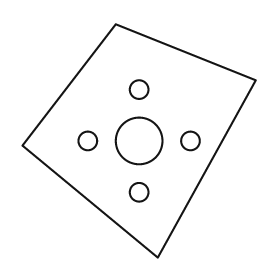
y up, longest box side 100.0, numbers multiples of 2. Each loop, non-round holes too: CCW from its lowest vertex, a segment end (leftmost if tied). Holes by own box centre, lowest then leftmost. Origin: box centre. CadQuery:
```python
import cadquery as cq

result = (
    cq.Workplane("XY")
    .moveTo(8.0, -50.0)
    .lineTo(50.0, 26.0)
    .lineTo(-10.0, 50.0)
    .lineTo(-50.0, -2.0)
    .close()
    .moveTo(0.0, -22.0)
    .circle(4.0)
    .moveTo(-22.0, 0.0)
    .circle(4.0)
    .moveTo(0.0, 0.0)
    .circle(10.0)
    .moveTo(22.0, 0.0)
    .circle(4.0)
    .moveTo(0.0, 22.0)
    .circle(4.0)
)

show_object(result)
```